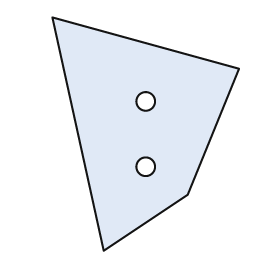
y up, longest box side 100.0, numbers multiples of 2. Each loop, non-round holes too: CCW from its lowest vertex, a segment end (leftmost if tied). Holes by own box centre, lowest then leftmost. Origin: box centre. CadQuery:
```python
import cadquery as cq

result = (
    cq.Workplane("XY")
    .moveTo(-18.0, -50.0)
    .lineTo(18.0, -26.0)
    .lineTo(40.0, 28.0)
    .lineTo(-40.0, 50.0)
    .close()
    .moveTo(0.0, -14.0)
    .circle(4.0)
    .moveTo(0.0, 14.0)
    .circle(4.0)
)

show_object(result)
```